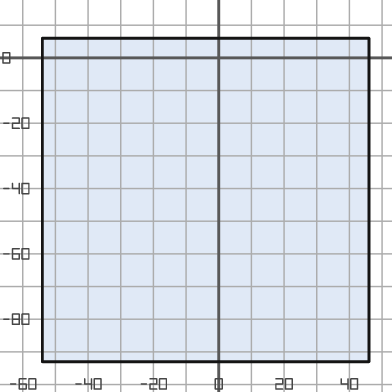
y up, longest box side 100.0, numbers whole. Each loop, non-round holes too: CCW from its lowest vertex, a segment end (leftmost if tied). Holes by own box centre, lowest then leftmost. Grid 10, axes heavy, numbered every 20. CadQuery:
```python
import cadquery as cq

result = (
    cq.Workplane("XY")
    .moveTo(-54.0, -93.0)
    .lineTo(46.0, -93.0)
    .lineTo(46.0, 6.0)
    .lineTo(-54.0, 6.0)
    .close()
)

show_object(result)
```